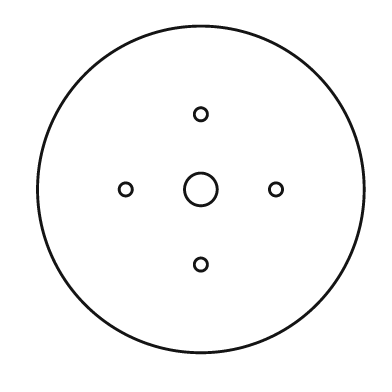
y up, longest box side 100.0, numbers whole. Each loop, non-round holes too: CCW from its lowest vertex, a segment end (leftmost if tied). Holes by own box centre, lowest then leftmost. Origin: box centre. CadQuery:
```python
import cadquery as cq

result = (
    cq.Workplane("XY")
    .moveTo(0.0, 0.0)
    .circle(50.0)
    .moveTo(0.0, -23.0)
    .circle(2.0)
    .moveTo(-23.0, 0.0)
    .circle(2.0)
    .moveTo(0.0, 0.0)
    .circle(5.0)
    .moveTo(23.0, 0.0)
    .circle(2.0)
    .moveTo(0.0, 23.0)
    .circle(2.0)
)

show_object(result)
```